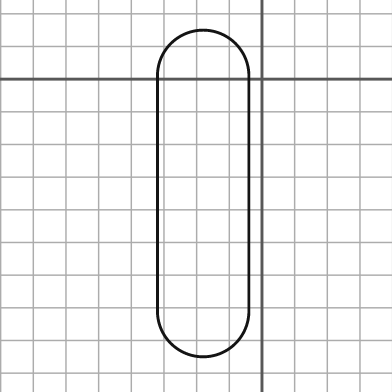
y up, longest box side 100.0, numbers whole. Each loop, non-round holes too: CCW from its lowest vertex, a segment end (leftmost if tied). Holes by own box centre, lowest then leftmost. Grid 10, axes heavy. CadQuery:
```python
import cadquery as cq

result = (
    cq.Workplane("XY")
    .moveTo(-32.0, -71.0)
    .threePointArc((-18.0, -85.0), (-4.0, -71.0))
    .lineTo(-4.0, 1.0)
    .threePointArc((-18.0, 15.0), (-32.0, 1.0))
    .close()
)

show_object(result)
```